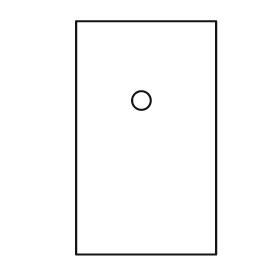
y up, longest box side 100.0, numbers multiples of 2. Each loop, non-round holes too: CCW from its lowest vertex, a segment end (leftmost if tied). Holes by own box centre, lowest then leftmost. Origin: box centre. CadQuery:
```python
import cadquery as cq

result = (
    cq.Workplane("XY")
    .moveTo(-30.0, -50.0)
    .lineTo(30.0, -50.0)
    .lineTo(30.0, 50.0)
    .lineTo(-30.0, 50.0)
    .close()
    .moveTo(-2.0, 16.0)
    .circle(4.0)
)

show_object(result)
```